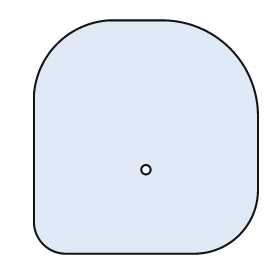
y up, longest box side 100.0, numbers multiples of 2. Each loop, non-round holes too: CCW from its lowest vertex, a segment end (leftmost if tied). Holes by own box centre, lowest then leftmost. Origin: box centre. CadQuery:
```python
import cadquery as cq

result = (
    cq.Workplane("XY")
    .moveTo(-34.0, -50.0)
    .lineTo(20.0, -50.0)
    .threePointArc((40.0, -42.0), (48.0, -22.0))
    .lineTo(48.0, 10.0)
    .threePointArc((36.0, 38.0), (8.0, 50.0))
    .lineTo(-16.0, 50.0)
    .threePointArc((-38.0, 40.0), (-48.0, 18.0))
    .lineTo(-48.0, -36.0)
    .threePointArc((-44.0, -46.0), (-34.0, -50.0))
    .close()
    .moveTo(0.0, -14.0)
    .circle(2.0)
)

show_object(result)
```